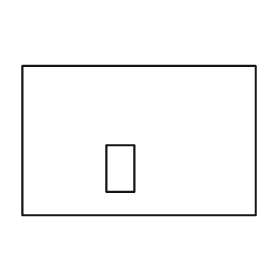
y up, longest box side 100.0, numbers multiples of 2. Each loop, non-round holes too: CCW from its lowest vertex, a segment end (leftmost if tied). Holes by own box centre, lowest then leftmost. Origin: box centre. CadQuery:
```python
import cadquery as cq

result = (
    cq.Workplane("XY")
    .moveTo(-50.0, -32.0)
    .lineTo(50.0, -32.0)
    .lineTo(50.0, 32.0)
    .lineTo(-50.0, 32.0)
    .close()
    .moveTo(-14.0, -22.0)
    .lineTo(-2.0, -22.0)
    .lineTo(-2.0, -2.0)
    .lineTo(-14.0, -2.0)
    .close()
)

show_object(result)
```